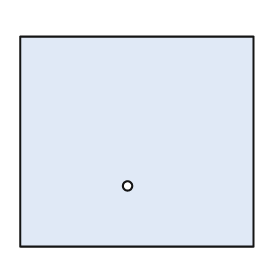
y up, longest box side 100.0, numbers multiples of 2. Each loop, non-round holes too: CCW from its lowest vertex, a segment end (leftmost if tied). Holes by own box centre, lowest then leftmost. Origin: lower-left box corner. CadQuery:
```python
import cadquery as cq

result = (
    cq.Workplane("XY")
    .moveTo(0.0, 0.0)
    .lineTo(100.0, 0.0)
    .lineTo(100.0, 90.0)
    .lineTo(0.0, 90.0)
    .close()
    .moveTo(46.0, 26.0)
    .circle(2.0)
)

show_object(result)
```